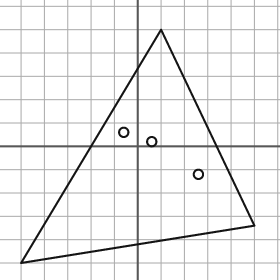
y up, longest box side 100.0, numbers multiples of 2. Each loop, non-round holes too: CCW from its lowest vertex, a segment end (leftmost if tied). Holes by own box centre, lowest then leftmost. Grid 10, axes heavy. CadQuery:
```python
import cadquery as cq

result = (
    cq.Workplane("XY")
    .moveTo(-50.0, -50.0)
    .lineTo(50.0, -34.0)
    .lineTo(10.0, 50.0)
    .close()
    .moveTo(26.0, -12.0)
    .circle(2.0)
    .moveTo(6.0, 2.0)
    .circle(2.0)
    .moveTo(-6.0, 6.0)
    .circle(2.0)
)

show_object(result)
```